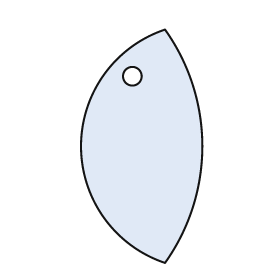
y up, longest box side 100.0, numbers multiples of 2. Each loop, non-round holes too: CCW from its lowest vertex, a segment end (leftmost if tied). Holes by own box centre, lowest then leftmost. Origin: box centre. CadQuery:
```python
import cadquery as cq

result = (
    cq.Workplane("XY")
    .moveTo(10.0, -50.0)
    .threePointArc((26.0, 0.0), (10.0, 50.0))
    .threePointArc((-26.0, 0.0), (10.0, -50.0))
    .close()
    .moveTo(-4.0, 30.0)
    .circle(4.0)
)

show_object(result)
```